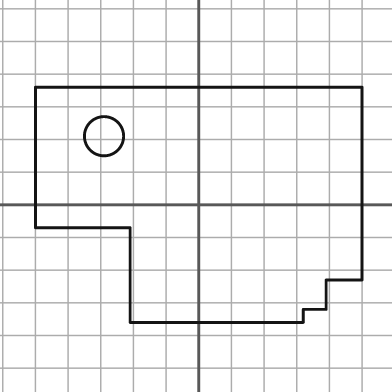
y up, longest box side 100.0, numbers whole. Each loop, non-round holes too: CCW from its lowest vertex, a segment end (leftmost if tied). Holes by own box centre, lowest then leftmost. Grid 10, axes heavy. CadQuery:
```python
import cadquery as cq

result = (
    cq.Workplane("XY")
    .moveTo(-21.0, -36.0)
    .lineTo(32.0, -36.0)
    .lineTo(32.0, -32.0)
    .lineTo(39.0, -32.0)
    .lineTo(39.0, -23.0)
    .lineTo(50.0, -23.0)
    .lineTo(50.0, 36.0)
    .lineTo(-50.0, 36.0)
    .lineTo(-50.0, -7.0)
    .lineTo(-21.0, -7.0)
    .close()
    .moveTo(-29.0, 21.0)
    .circle(6.0)
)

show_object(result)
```